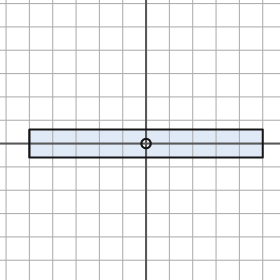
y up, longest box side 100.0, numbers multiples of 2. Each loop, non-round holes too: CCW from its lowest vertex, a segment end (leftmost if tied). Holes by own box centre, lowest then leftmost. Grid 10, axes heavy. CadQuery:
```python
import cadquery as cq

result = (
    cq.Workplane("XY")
    .moveTo(-50.0, -6.0)
    .lineTo(50.0, -6.0)
    .lineTo(50.0, 6.0)
    .lineTo(-50.0, 6.0)
    .close()
    .moveTo(0.0, 0.0)
    .circle(2.0)
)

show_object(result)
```